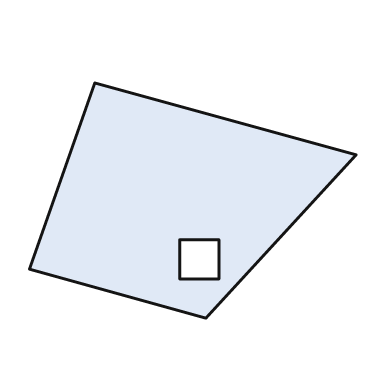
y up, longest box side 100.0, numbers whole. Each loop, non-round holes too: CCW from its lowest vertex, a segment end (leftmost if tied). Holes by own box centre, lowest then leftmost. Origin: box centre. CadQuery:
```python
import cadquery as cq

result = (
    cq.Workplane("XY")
    .moveTo(4.0, -36.0)
    .lineTo(50.0, 14.0)
    .lineTo(-30.0, 36.0)
    .lineTo(-50.0, -21.0)
    .close()
    .moveTo(-4.0, -24.0)
    .lineTo(8.0, -24.0)
    .lineTo(8.0, -12.0)
    .lineTo(-4.0, -12.0)
    .close()
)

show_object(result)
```